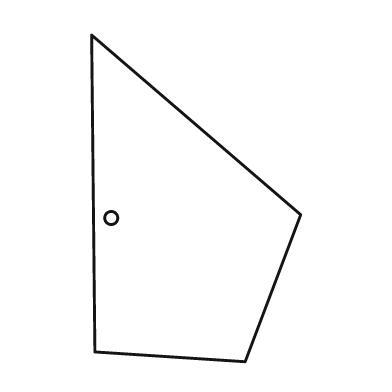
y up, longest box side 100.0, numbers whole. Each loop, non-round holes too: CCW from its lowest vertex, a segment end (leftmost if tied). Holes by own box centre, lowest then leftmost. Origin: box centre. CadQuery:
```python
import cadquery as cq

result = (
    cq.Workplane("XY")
    .moveTo(15.0, -50.0)
    .lineTo(32.0, -5.0)
    .lineTo(-32.0, 50.0)
    .lineTo(-31.0, -47.0)
    .close()
    .moveTo(-26.0, -6.0)
    .circle(2.0)
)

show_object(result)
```